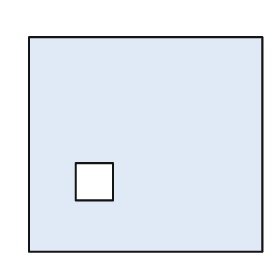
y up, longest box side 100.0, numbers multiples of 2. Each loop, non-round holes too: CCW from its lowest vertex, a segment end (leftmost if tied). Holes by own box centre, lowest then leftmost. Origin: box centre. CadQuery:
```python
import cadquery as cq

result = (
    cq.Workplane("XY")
    .moveTo(-50.0, -46.0)
    .lineTo(50.0, -46.0)
    .lineTo(50.0, 46.0)
    .lineTo(-50.0, 46.0)
    .close()
    .moveTo(-30.0, -24.0)
    .lineTo(-14.0, -24.0)
    .lineTo(-14.0, -8.0)
    .lineTo(-30.0, -8.0)
    .close()
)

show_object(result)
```